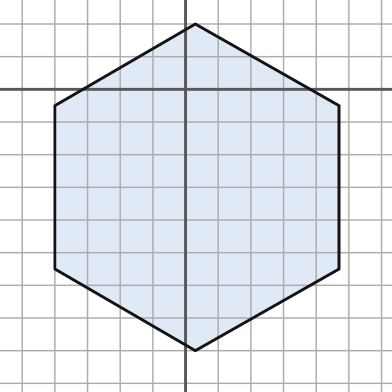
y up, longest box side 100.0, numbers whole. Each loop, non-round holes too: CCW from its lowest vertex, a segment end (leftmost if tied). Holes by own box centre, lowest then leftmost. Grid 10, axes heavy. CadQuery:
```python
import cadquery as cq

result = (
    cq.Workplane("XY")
    .moveTo(3.0, -80.0)
    .lineTo(47.0, -55.0)
    .lineTo(47.0, -5.0)
    .lineTo(3.0, 20.0)
    .lineTo(-40.0, -5.0)
    .lineTo(-40.0, -55.0)
    .close()
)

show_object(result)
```